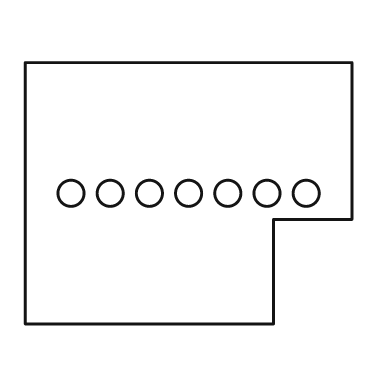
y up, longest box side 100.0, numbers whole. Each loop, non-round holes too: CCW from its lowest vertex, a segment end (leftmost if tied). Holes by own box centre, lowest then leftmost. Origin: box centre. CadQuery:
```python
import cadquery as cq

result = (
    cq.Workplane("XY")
    .moveTo(-50.0, -40.0)
    .lineTo(26.0, -40.0)
    .lineTo(26.0, -8.0)
    .lineTo(50.0, -8.0)
    .lineTo(50.0, 40.0)
    .lineTo(-50.0, 40.0)
    .close()
    .moveTo(-36.0, 0.0)
    .circle(4.0)
    .moveTo(-24.0, 0.0)
    .circle(4.0)
    .moveTo(-12.0, 0.0)
    .circle(4.0)
    .moveTo(0.0, 0.0)
    .circle(4.0)
    .moveTo(12.0, 0.0)
    .circle(4.0)
    .moveTo(24.0, 0.0)
    .circle(4.0)
    .moveTo(36.0, 0.0)
    .circle(4.0)
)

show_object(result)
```